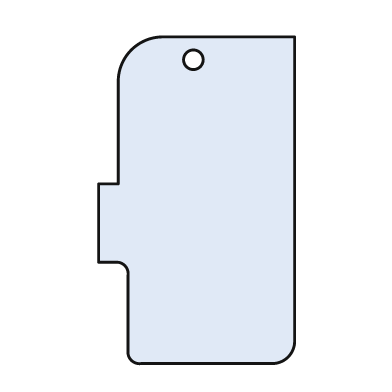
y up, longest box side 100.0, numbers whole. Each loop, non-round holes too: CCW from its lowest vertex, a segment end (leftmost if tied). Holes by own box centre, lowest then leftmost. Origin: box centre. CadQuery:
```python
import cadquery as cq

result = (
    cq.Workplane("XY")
    .moveTo(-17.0, -50.0)
    .lineTo(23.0, -50.0)
    .threePointArc((28.0, -48.0), (30.0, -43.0))
    .lineTo(30.0, 50.0)
    .lineTo(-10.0, 50.0)
    .threePointArc((-20.0, 46.0), (-24.0, 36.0))
    .lineTo(-24.0, 5.0)
    .lineTo(-30.0, 5.0)
    .lineTo(-30.0, -19.0)
    .lineTo(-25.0, -19.0)
    .threePointArc((-22.0, -20.0), (-21.0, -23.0))
    .lineTo(-21.0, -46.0)
    .threePointArc((-20.0, -49.0), (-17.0, -50.0))
    .close()
    .moveTo(-1.0, 43.0)
    .circle(3.0)
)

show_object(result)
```